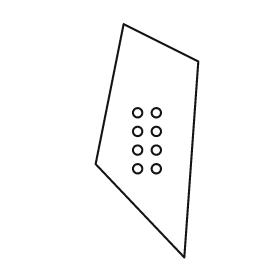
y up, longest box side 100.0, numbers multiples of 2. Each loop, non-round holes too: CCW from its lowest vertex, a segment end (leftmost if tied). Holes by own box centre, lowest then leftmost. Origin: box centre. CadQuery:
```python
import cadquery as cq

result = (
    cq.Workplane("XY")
    .moveTo(16.0, -50.0)
    .lineTo(22.0, 34.0)
    .lineTo(-10.0, 50.0)
    .lineTo(-22.0, -10.0)
    .close()
    .moveTo(-4.0, -12.0)
    .circle(2.0)
    .moveTo(4.0, -12.0)
    .circle(2.0)
    .moveTo(-4.0, -4.0)
    .circle(2.0)
    .moveTo(4.0, -4.0)
    .circle(2.0)
    .moveTo(-4.0, 4.0)
    .circle(2.0)
    .moveTo(4.0, 4.0)
    .circle(2.0)
    .moveTo(-4.0, 12.0)
    .circle(2.0)
    .moveTo(4.0, 12.0)
    .circle(2.0)
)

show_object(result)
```